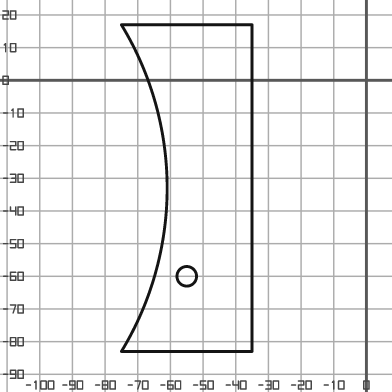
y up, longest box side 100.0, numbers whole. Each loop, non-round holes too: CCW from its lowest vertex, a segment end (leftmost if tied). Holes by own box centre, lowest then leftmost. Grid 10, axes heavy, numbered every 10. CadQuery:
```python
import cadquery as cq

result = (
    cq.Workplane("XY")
    .moveTo(-75.0, -83.0)
    .lineTo(-35.0, -83.0)
    .lineTo(-35.0, 17.0)
    .lineTo(-75.0, 17.0)
    .threePointArc((-61.0, -33.0), (-75.0, -83.0))
    .close()
    .moveTo(-55.0, -60.0)
    .circle(3.0)
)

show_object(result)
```